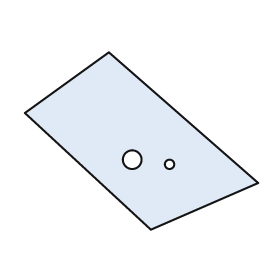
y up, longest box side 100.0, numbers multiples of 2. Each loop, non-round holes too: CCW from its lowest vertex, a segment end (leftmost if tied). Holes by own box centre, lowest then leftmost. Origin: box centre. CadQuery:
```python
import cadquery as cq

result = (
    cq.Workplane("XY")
    .moveTo(4.0, -38.0)
    .lineTo(50.0, -18.0)
    .lineTo(-14.0, 38.0)
    .lineTo(-50.0, 12.0)
    .close()
    .moveTo(12.0, -10.0)
    .circle(2.0)
    .moveTo(-4.0, -8.0)
    .circle(4.0)
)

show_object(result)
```